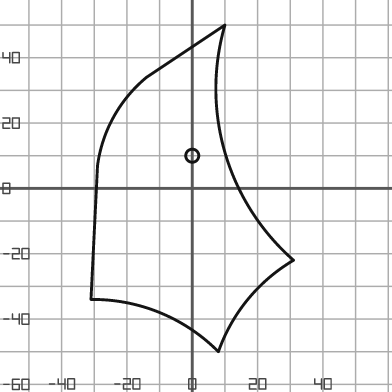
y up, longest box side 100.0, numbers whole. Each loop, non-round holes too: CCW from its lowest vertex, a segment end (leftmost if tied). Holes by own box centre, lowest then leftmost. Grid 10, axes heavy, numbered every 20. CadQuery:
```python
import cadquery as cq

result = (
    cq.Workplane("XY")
    .moveTo(8.0, -50.0)
    .threePointArc((17.0, -34.0), (31.0, -22.0))
    .threePointArc((10.0, 11.0), (10.0, 50.0))
    .lineTo(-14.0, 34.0)
    .threePointArc((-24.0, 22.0), (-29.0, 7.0))
    .lineTo(-31.0, -34.0)
    .threePointArc((-10.0, -38.0), (8.0, -50.0))
    .close()
    .moveTo(0.0, 10.0)
    .circle(2.0)
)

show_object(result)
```